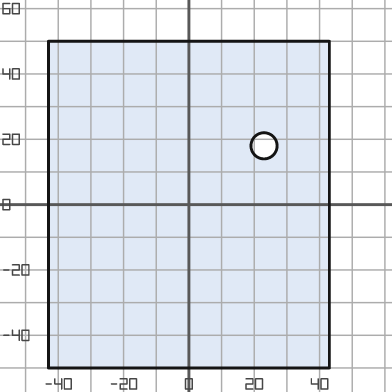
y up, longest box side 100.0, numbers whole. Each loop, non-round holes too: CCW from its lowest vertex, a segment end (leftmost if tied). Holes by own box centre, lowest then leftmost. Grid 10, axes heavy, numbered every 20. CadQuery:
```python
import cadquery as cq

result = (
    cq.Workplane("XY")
    .moveTo(-43.0, -50.0)
    .lineTo(43.0, -50.0)
    .lineTo(43.0, 50.0)
    .lineTo(-43.0, 50.0)
    .close()
    .moveTo(23.0, 18.0)
    .circle(4.0)
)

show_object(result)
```